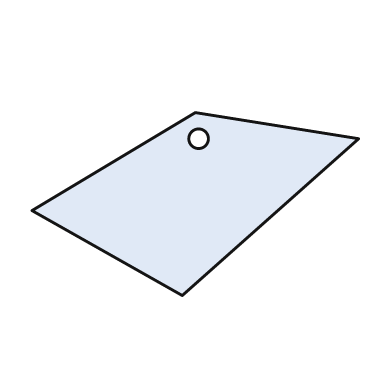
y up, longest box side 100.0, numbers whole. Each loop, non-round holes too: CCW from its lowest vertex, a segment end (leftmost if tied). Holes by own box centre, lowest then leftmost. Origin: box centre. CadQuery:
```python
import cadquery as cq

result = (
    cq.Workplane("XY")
    .moveTo(-4.0, -28.0)
    .lineTo(50.0, 20.0)
    .lineTo(0.0, 28.0)
    .lineTo(-50.0, -2.0)
    .close()
    .moveTo(1.0, 20.0)
    .circle(3.0)
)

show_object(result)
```